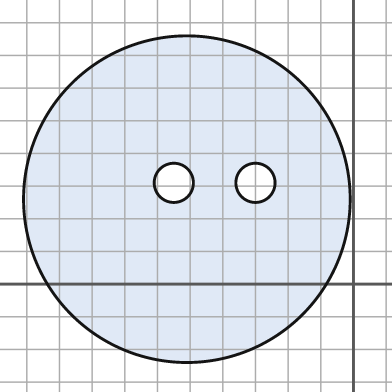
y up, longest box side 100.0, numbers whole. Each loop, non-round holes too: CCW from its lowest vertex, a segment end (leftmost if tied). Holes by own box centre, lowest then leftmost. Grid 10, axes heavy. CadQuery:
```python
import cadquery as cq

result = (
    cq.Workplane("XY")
    .moveTo(-51.0, 26.0)
    .circle(50.0)
    .moveTo(-55.0, 31.0)
    .circle(6.0)
    .moveTo(-30.0, 31.0)
    .circle(6.0)
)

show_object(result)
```